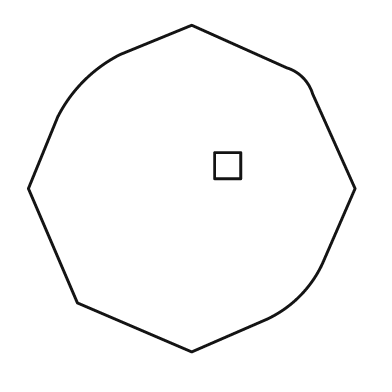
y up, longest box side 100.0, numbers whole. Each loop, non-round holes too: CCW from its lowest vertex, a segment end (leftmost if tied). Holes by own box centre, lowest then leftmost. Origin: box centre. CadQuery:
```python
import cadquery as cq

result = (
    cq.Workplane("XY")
    .moveTo(0.0, -50.0)
    .lineTo(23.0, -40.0)
    .threePointArc((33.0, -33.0), (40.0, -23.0))
    .lineTo(50.0, 0.0)
    .lineTo(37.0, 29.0)
    .threePointArc((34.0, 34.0), (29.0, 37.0))
    .lineTo(0.0, 50.0)
    .lineTo(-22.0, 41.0)
    .threePointArc((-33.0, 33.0), (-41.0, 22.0))
    .lineTo(-50.0, 0.0)
    .lineTo(-35.0, -35.0)
    .close()
    .moveTo(7.0, 3.0)
    .lineTo(15.0, 3.0)
    .lineTo(15.0, 11.0)
    .lineTo(7.0, 11.0)
    .close()
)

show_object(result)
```